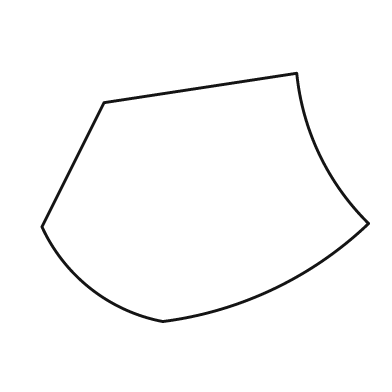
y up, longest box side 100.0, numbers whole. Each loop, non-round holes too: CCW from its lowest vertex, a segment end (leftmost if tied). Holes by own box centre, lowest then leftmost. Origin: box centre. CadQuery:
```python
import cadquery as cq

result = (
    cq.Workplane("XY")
    .moveTo(-13.0, -38.0)
    .threePointArc((21.0, -28.0), (50.0, -8.0))
    .threePointArc((35.0, 13.0), (28.0, 38.0))
    .lineTo(-31.0, 29.0)
    .lineTo(-50.0, -9.0)
    .threePointArc((-35.0, -28.0), (-13.0, -38.0))
    .close()
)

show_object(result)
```